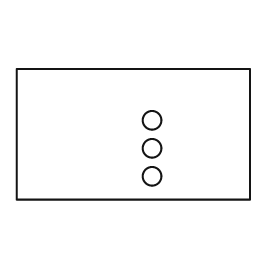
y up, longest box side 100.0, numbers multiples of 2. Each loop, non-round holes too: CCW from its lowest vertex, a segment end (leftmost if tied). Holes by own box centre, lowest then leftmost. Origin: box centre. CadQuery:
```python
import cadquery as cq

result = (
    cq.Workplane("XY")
    .moveTo(-50.0, -28.0)
    .lineTo(50.0, -28.0)
    .lineTo(50.0, 28.0)
    .lineTo(-50.0, 28.0)
    .close()
    .moveTo(8.0, -18.0)
    .circle(4.0)
    .moveTo(8.0, -6.0)
    .circle(4.0)
    .moveTo(8.0, 6.0)
    .circle(4.0)
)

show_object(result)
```